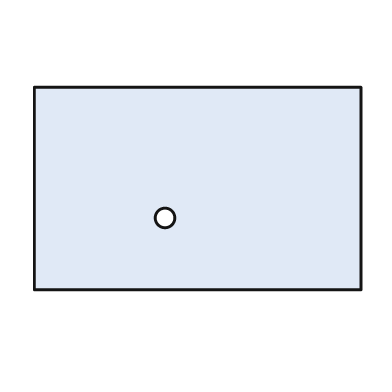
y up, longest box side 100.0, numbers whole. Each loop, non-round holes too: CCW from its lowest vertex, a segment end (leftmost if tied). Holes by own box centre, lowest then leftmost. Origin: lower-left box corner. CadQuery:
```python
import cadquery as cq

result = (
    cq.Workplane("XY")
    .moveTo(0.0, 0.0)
    .lineTo(100.0, 0.0)
    .lineTo(100.0, 62.0)
    .lineTo(0.0, 62.0)
    .close()
    .moveTo(40.0, 22.0)
    .circle(3.0)
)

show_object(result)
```